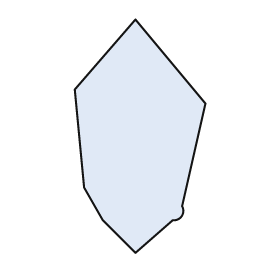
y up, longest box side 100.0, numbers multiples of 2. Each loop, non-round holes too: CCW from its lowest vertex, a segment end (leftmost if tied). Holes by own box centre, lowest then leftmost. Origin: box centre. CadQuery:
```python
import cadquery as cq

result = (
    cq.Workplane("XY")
    .moveTo(-2.0, -50.0)
    .lineTo(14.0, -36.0)
    .threePointArc((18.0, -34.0), (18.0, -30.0))
    .lineTo(28.0, 14.0)
    .lineTo(-2.0, 50.0)
    .lineTo(-28.0, 20.0)
    .lineTo(-24.0, -22.0)
    .lineTo(-16.0, -36.0)
    .close()
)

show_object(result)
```